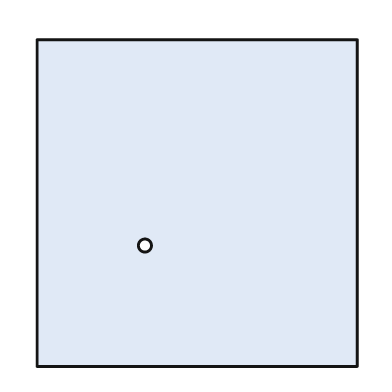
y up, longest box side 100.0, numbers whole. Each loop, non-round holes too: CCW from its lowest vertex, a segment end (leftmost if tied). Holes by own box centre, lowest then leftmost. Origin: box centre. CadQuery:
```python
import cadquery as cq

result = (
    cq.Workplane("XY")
    .moveTo(-49.0, -50.0)
    .lineTo(49.0, -50.0)
    .lineTo(49.0, 50.0)
    .lineTo(-49.0, 50.0)
    .close()
    .moveTo(-16.0, -13.0)
    .circle(2.0)
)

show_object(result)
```